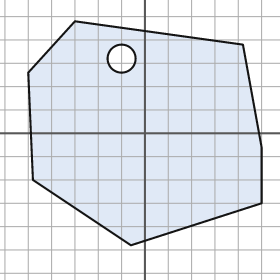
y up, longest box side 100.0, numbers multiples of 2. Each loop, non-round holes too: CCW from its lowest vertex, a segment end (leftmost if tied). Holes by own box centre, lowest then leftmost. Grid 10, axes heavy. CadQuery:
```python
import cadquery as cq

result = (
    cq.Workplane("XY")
    .moveTo(-6.0, -48.0)
    .lineTo(50.0, -30.0)
    .lineTo(50.0, -6.0)
    .lineTo(42.0, 38.0)
    .lineTo(-30.0, 48.0)
    .lineTo(-50.0, 26.0)
    .lineTo(-48.0, -20.0)
    .close()
    .moveTo(-10.0, 32.0)
    .circle(6.0)
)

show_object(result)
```